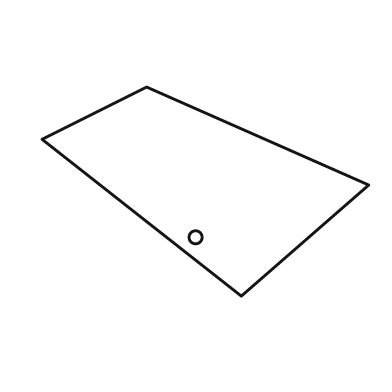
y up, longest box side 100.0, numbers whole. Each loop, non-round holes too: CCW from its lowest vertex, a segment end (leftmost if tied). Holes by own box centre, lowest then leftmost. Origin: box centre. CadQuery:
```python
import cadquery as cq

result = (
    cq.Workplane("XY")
    .moveTo(11.0, -32.0)
    .lineTo(50.0, 2.0)
    .lineTo(-18.0, 32.0)
    .lineTo(-50.0, 16.0)
    .close()
    .moveTo(-3.0, -14.0)
    .circle(2.0)
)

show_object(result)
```